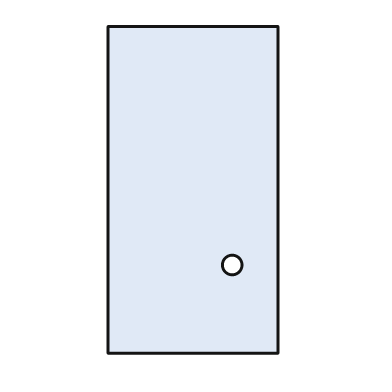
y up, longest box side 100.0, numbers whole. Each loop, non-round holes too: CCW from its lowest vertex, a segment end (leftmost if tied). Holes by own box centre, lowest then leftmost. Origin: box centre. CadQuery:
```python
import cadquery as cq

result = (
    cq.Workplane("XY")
    .moveTo(-26.0, -50.0)
    .lineTo(26.0, -50.0)
    .lineTo(26.0, 50.0)
    .lineTo(-26.0, 50.0)
    .close()
    .moveTo(12.0, -23.0)
    .circle(3.0)
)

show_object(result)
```